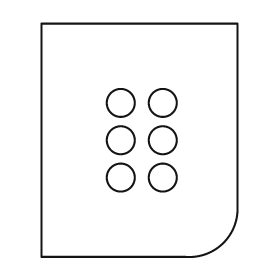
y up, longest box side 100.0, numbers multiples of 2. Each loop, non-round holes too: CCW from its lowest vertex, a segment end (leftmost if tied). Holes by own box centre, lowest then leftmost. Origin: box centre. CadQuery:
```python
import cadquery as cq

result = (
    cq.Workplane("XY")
    .moveTo(-42.0, -50.0)
    .lineTo(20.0, -50.0)
    .threePointArc((36.0, -44.0), (42.0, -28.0))
    .lineTo(42.0, 50.0)
    .lineTo(-42.0, 50.0)
    .close()
    .moveTo(-8.0, -16.0)
    .circle(6.0)
    .moveTo(10.0, -16.0)
    .circle(6.0)
    .moveTo(-8.0, 0.0)
    .circle(6.0)
    .moveTo(10.0, 0.0)
    .circle(6.0)
    .moveTo(-8.0, 16.0)
    .circle(6.0)
    .moveTo(10.0, 16.0)
    .circle(6.0)
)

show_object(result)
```